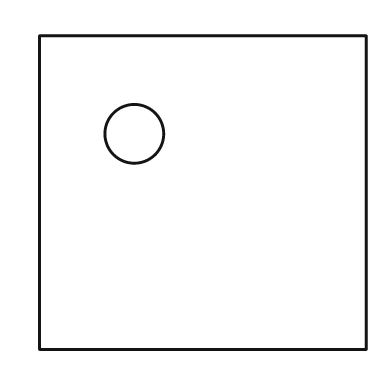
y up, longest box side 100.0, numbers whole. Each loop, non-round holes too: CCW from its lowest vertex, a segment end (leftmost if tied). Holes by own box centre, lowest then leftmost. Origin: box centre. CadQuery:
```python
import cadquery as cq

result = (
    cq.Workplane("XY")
    .moveTo(-50.0, -48.0)
    .lineTo(50.0, -48.0)
    .lineTo(50.0, 48.0)
    .lineTo(-50.0, 48.0)
    .close()
    .moveTo(-21.0, 18.0)
    .circle(9.0)
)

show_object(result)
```